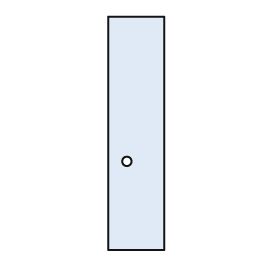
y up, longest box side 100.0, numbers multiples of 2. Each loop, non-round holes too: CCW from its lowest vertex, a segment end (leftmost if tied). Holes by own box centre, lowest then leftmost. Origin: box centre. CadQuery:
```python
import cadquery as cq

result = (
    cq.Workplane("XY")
    .moveTo(-12.0, -50.0)
    .lineTo(12.0, -50.0)
    .lineTo(12.0, 50.0)
    .lineTo(-12.0, 50.0)
    .close()
    .moveTo(-4.0, -12.0)
    .circle(2.0)
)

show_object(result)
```